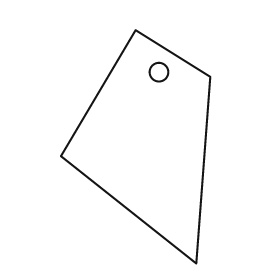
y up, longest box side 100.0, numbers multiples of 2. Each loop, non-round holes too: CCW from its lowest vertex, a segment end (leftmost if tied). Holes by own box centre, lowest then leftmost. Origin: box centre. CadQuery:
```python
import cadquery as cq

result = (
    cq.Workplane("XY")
    .moveTo(26.0, -50.0)
    .lineTo(32.0, 30.0)
    .lineTo(0.0, 50.0)
    .lineTo(-32.0, -4.0)
    .close()
    .moveTo(10.0, 32.0)
    .circle(4.0)
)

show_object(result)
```